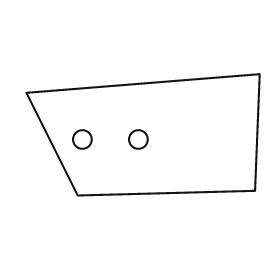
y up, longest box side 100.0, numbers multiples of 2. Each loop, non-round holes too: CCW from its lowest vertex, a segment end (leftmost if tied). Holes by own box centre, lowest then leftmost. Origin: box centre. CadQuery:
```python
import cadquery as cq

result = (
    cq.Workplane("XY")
    .moveTo(-28.0, -26.0)
    .lineTo(48.0, -24.0)
    .lineTo(50.0, 26.0)
    .lineTo(-50.0, 18.0)
    .close()
    .moveTo(-26.0, -2.0)
    .circle(4.0)
    .moveTo(-2.0, -2.0)
    .circle(4.0)
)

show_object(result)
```